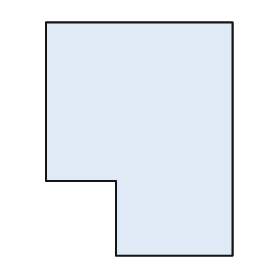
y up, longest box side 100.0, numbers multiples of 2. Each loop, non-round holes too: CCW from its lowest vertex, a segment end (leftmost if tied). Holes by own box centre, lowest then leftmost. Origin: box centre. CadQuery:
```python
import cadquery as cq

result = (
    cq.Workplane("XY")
    .moveTo(-10.0, -50.0)
    .lineTo(40.0, -50.0)
    .lineTo(40.0, 50.0)
    .lineTo(-40.0, 50.0)
    .lineTo(-40.0, -18.0)
    .lineTo(-10.0, -18.0)
    .close()
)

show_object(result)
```